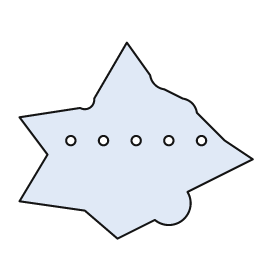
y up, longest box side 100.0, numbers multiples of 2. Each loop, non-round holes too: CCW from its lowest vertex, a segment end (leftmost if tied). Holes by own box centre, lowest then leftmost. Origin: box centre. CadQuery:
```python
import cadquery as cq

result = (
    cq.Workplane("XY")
    .moveTo(-8.0, -42.0)
    .lineTo(8.0, -34.0)
    .threePointArc((20.0, -34.0), (22.0, -22.0))
    .lineTo(50.0, -8.0)
    .lineTo(38.0, 0.0)
    .lineTo(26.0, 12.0)
    .threePointArc((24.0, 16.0), (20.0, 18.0))
    .lineTo(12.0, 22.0)
    .threePointArc((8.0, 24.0), (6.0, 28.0))
    .lineTo(-4.0, 42.0)
    .lineTo(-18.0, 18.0)
    .threePointArc((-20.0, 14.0), (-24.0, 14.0))
    .lineTo(-50.0, 10.0)
    .lineTo(-38.0, -6.0)
    .lineTo(-50.0, -26.0)
    .lineTo(-22.0, -30.0)
    .close()
    .moveTo(-28.0, 0.0)
    .circle(2.0)
    .moveTo(-14.0, 0.0)
    .circle(2.0)
    .moveTo(0.0, 0.0)
    .circle(2.0)
    .moveTo(14.0, 0.0)
    .circle(2.0)
    .moveTo(28.0, 0.0)
    .circle(2.0)
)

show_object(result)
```